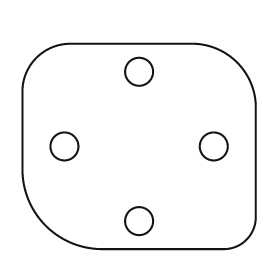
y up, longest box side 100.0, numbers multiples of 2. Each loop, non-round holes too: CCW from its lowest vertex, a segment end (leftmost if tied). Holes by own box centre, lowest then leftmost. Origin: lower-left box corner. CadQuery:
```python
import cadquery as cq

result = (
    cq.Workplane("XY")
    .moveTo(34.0, 0.0)
    .lineTo(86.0, 0.0)
    .threePointArc((96.0, 4.0), (100.0, 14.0))
    .lineTo(100.0, 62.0)
    .threePointArc((92.0, 80.0), (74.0, 88.0))
    .lineTo(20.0, 88.0)
    .threePointArc((6.0, 82.0), (0.0, 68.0))
    .lineTo(0.0, 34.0)
    .threePointArc((10.0, 10.0), (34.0, 0.0))
    .close()
    .moveTo(50.0, 12.0)
    .circle(6.0)
    .moveTo(18.0, 44.0)
    .circle(6.0)
    .moveTo(82.0, 44.0)
    .circle(6.0)
    .moveTo(50.0, 76.0)
    .circle(6.0)
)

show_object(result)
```